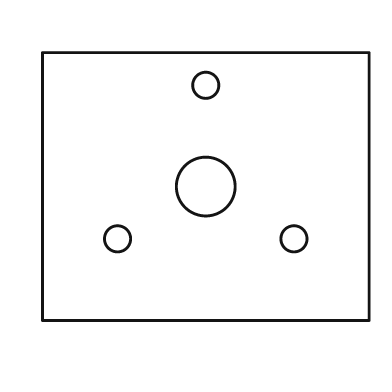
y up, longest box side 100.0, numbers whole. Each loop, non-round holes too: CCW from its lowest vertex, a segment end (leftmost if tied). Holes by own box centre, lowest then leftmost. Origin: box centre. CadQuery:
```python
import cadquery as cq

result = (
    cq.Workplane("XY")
    .moveTo(-50.0, -41.0)
    .lineTo(50.0, -41.0)
    .lineTo(50.0, 41.0)
    .lineTo(-50.0, 41.0)
    .close()
    .moveTo(-27.0, -16.0)
    .circle(4.0)
    .moveTo(27.0, -16.0)
    .circle(4.0)
    .moveTo(0.0, 0.0)
    .circle(9.0)
    .moveTo(0.0, 31.0)
    .circle(4.0)
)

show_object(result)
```